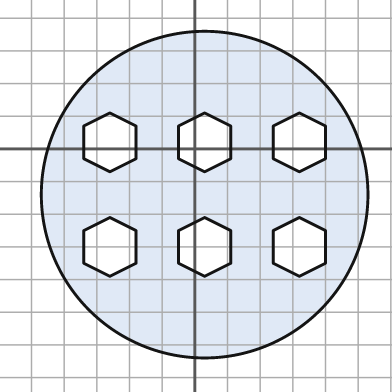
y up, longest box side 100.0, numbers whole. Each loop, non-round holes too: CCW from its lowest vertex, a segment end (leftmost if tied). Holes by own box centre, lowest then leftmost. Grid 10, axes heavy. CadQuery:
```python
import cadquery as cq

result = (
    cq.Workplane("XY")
    .moveTo(3.0, -14.0)
    .circle(50.0)
    .moveTo(-26.0, -39.0)
    .lineTo(-18.0, -35.0)
    .lineTo(-18.0, -25.0)
    .lineTo(-26.0, -21.0)
    .lineTo(-34.0, -25.0)
    .lineTo(-34.0, -35.0)
    .close()
    .moveTo(3.0, -39.0)
    .lineTo(11.0, -35.0)
    .lineTo(11.0, -25.0)
    .lineTo(3.0, -21.0)
    .lineTo(-5.0, -25.0)
    .lineTo(-5.0, -35.0)
    .close()
    .moveTo(32.0, -39.0)
    .lineTo(40.0, -35.0)
    .lineTo(40.0, -25.0)
    .lineTo(32.0, -21.0)
    .lineTo(24.0, -25.0)
    .lineTo(24.0, -35.0)
    .close()
    .moveTo(-26.0, -7.0)
    .lineTo(-18.0, -3.0)
    .lineTo(-18.0, 7.0)
    .lineTo(-26.0, 11.0)
    .lineTo(-34.0, 7.0)
    .lineTo(-34.0, -3.0)
    .close()
    .moveTo(3.0, -7.0)
    .lineTo(11.0, -3.0)
    .lineTo(11.0, 7.0)
    .lineTo(3.0, 11.0)
    .lineTo(-5.0, 7.0)
    .lineTo(-5.0, -3.0)
    .close()
    .moveTo(32.0, -7.0)
    .lineTo(40.0, -3.0)
    .lineTo(40.0, 7.0)
    .lineTo(32.0, 11.0)
    .lineTo(24.0, 7.0)
    .lineTo(24.0, -3.0)
    .close()
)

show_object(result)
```